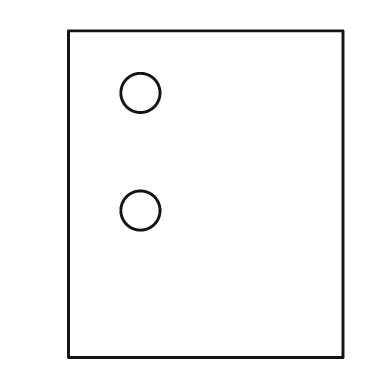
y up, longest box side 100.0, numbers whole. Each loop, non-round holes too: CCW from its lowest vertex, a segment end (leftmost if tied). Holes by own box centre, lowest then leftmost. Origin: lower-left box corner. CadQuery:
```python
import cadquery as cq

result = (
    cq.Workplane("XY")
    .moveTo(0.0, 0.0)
    .lineTo(84.0, 0.0)
    .lineTo(84.0, 100.0)
    .lineTo(0.0, 100.0)
    .close()
    .moveTo(22.0, 45.0)
    .circle(6.0)
    .moveTo(22.0, 81.0)
    .circle(6.0)
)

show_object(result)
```